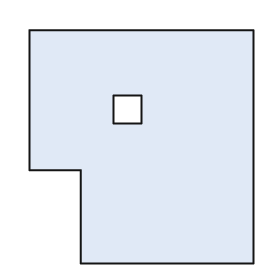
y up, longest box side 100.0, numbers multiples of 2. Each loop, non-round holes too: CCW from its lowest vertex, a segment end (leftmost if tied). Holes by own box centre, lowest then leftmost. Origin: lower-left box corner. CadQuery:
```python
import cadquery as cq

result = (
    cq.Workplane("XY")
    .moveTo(22.0, 0.0)
    .lineTo(96.0, 0.0)
    .lineTo(96.0, 100.0)
    .lineTo(0.0, 100.0)
    .lineTo(0.0, 40.0)
    .lineTo(22.0, 40.0)
    .close()
    .moveTo(36.0, 60.0)
    .lineTo(48.0, 60.0)
    .lineTo(48.0, 72.0)
    .lineTo(36.0, 72.0)
    .close()
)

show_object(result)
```